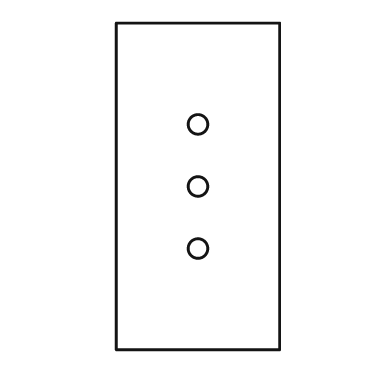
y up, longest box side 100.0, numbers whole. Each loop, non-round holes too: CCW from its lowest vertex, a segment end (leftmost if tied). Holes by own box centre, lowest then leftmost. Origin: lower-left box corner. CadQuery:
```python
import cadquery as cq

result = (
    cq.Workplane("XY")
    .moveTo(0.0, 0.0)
    .lineTo(50.0, 0.0)
    .lineTo(50.0, 100.0)
    .lineTo(0.0, 100.0)
    .close()
    .moveTo(25.0, 31.0)
    .circle(3.0)
    .moveTo(25.0, 50.0)
    .circle(3.0)
    .moveTo(25.0, 69.0)
    .circle(3.0)
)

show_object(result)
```